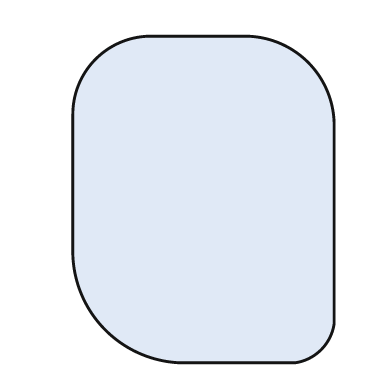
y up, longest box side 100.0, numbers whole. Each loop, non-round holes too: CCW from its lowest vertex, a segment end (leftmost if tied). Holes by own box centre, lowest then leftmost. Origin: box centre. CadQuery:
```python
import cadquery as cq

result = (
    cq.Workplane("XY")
    .moveTo(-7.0, -50.0)
    .lineTo(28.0, -50.0)
    .threePointArc((36.0, -46.0), (40.0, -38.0))
    .lineTo(40.0, 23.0)
    .threePointArc((32.0, 42.0), (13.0, 50.0))
    .lineTo(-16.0, 50.0)
    .threePointArc((-33.0, 43.0), (-40.0, 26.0))
    .lineTo(-40.0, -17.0)
    .threePointArc((-30.0, -40.0), (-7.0, -50.0))
    .close()
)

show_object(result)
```